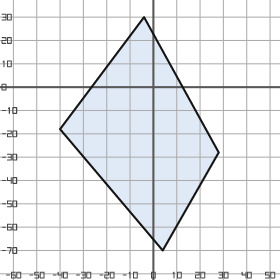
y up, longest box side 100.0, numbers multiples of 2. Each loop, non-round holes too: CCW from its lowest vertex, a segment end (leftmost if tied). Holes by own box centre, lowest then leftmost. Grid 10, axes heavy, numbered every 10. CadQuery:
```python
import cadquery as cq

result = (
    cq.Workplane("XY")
    .moveTo(4.0, -70.0)
    .lineTo(28.0, -28.0)
    .lineTo(-4.0, 30.0)
    .lineTo(-40.0, -18.0)
    .close()
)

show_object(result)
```